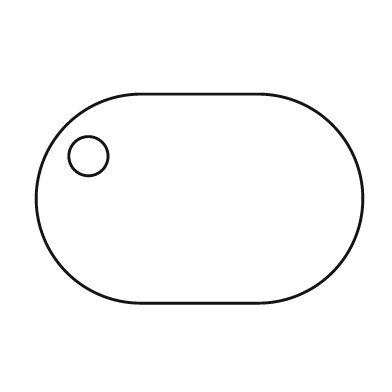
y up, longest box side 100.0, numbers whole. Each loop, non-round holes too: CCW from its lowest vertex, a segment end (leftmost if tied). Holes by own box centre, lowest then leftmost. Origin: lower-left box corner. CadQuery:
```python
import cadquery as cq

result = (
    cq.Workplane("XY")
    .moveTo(32.0, 0.0)
    .lineTo(68.0, 0.0)
    .threePointArc((100.0, 32.0), (68.0, 64.0))
    .lineTo(32.0, 64.0)
    .threePointArc((0.0, 32.0), (32.0, 0.0))
    .close()
    .moveTo(16.0, 45.0)
    .circle(6.0)
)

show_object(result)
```